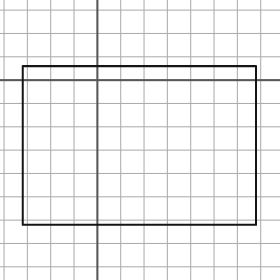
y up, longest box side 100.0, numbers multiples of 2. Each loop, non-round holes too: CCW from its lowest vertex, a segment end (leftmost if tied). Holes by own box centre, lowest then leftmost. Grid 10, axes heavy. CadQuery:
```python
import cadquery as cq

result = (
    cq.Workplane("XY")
    .moveTo(-32.0, -62.0)
    .lineTo(68.0, -62.0)
    .lineTo(68.0, 6.0)
    .lineTo(-32.0, 6.0)
    .close()
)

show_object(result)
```